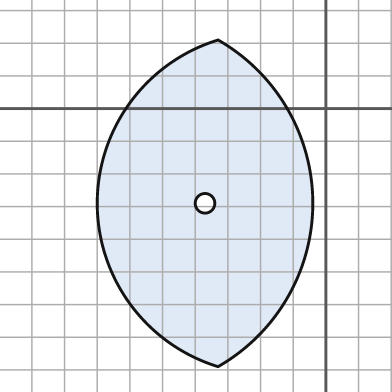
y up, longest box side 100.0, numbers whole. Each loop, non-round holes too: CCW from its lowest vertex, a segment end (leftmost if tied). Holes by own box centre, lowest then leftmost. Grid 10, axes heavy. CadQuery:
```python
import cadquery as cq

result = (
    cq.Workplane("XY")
    .moveTo(-33.0, -79.0)
    .threePointArc((-4.0, -29.0), (-33.0, 21.0))
    .threePointArc((-70.0, -29.0), (-33.0, -79.0))
    .close()
    .moveTo(-37.0, -29.0)
    .circle(3.0)
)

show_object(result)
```